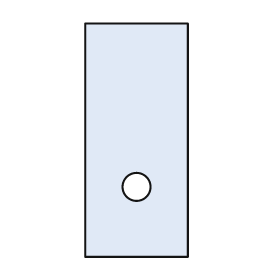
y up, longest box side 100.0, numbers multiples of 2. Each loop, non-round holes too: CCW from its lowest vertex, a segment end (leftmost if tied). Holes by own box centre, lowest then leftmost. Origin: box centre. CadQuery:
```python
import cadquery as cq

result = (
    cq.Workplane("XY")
    .moveTo(-22.0, -50.0)
    .lineTo(22.0, -50.0)
    .lineTo(22.0, 50.0)
    .lineTo(-22.0, 50.0)
    .close()
    .moveTo(0.0, -20.0)
    .circle(6.0)
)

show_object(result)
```